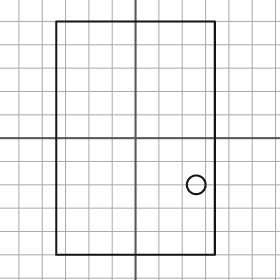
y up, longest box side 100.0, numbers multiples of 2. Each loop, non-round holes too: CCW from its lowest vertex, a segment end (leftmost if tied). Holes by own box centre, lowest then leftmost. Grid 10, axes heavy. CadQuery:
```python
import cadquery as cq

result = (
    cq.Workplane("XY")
    .moveTo(-34.0, -50.0)
    .lineTo(34.0, -50.0)
    .lineTo(34.0, 50.0)
    .lineTo(-34.0, 50.0)
    .close()
    .moveTo(26.0, -20.0)
    .circle(4.0)
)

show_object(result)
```